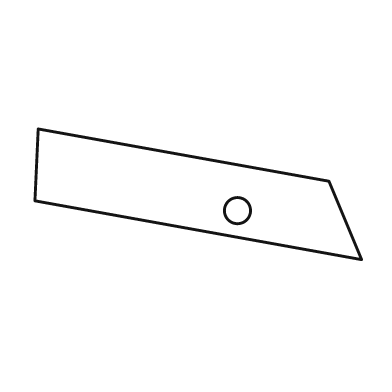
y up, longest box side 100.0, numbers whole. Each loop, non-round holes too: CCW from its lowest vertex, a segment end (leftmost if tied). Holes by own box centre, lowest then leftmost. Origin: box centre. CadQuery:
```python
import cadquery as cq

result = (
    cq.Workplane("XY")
    .moveTo(50.0, -20.0)
    .lineTo(40.0, 4.0)
    .lineTo(-49.0, 20.0)
    .lineTo(-50.0, -2.0)
    .close()
    .moveTo(12.0, -5.0)
    .circle(4.0)
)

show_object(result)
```